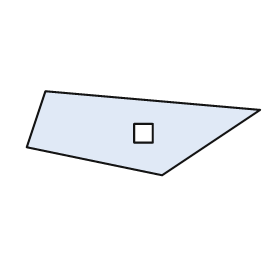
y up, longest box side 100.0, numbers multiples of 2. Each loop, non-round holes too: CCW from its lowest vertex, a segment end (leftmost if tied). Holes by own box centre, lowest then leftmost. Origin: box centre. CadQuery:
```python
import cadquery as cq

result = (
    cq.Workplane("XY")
    .moveTo(8.0, -18.0)
    .lineTo(50.0, 10.0)
    .lineTo(-42.0, 18.0)
    .lineTo(-50.0, -6.0)
    .close()
    .moveTo(-4.0, -4.0)
    .lineTo(4.0, -4.0)
    .lineTo(4.0, 4.0)
    .lineTo(-4.0, 4.0)
    .close()
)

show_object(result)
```